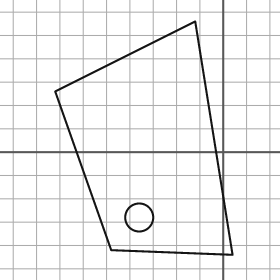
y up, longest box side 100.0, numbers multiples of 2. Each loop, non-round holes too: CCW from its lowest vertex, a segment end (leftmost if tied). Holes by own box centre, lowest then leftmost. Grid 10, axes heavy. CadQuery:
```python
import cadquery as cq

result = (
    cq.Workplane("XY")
    .moveTo(4.0, -44.0)
    .lineTo(-12.0, 56.0)
    .lineTo(-72.0, 26.0)
    .lineTo(-48.0, -42.0)
    .close()
    .moveTo(-36.0, -28.0)
    .circle(6.0)
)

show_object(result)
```